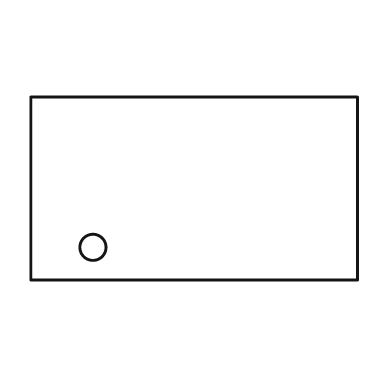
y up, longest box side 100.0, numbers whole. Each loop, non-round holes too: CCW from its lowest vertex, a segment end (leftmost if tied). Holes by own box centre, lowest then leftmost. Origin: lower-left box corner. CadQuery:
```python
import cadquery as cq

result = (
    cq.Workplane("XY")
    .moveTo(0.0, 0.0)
    .lineTo(100.0, 0.0)
    .lineTo(100.0, 56.0)
    .lineTo(0.0, 56.0)
    .close()
    .moveTo(19.0, 10.0)
    .circle(4.0)
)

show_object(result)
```